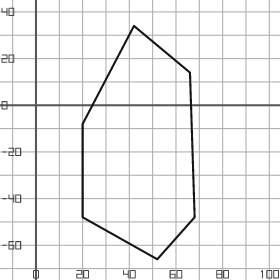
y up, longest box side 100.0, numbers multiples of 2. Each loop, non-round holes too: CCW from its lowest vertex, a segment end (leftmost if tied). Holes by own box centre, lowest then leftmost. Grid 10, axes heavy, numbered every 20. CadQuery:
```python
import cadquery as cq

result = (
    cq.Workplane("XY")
    .moveTo(52.0, -66.0)
    .lineTo(68.0, -48.0)
    .lineTo(66.0, 14.0)
    .lineTo(42.0, 34.0)
    .lineTo(20.0, -8.0)
    .lineTo(20.0, -48.0)
    .close()
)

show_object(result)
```